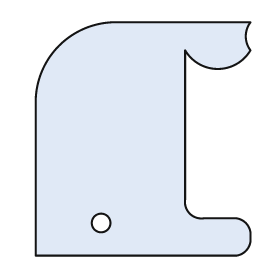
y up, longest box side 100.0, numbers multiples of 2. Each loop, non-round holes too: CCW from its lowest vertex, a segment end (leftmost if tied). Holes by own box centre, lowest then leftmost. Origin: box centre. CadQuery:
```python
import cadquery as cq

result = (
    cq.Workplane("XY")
    .moveTo(-46.0, -50.0)
    .lineTo(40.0, -50.0)
    .threePointArc((44.0, -48.0), (46.0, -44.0))
    .lineTo(46.0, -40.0)
    .threePointArc((44.0, -36.0), (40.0, -34.0))
    .lineTo(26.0, -34.0)
    .threePointArc((20.0, -32.0), (18.0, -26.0))
    .lineTo(18.0, 38.0)
    .threePointArc((32.0, 30.0), (46.0, 38.0))
    .threePointArc((44.0, 44.0), (46.0, 50.0))
    .lineTo(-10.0, 50.0)
    .threePointArc((-36.0, 40.0), (-46.0, 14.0))
    .close()
    .moveTo(-18.0, -36.0)
    .circle(4.0)
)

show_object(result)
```